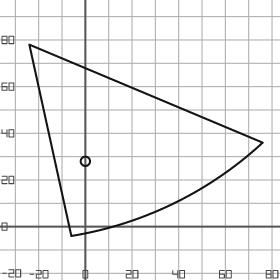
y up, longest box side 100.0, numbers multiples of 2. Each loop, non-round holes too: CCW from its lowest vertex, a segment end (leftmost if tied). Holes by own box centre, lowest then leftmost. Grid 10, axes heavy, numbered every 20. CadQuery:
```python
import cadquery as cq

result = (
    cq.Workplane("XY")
    .moveTo(-6.0, -4.0)
    .threePointArc((38.0, 10.0), (76.0, 36.0))
    .lineTo(-24.0, 78.0)
    .close()
    .moveTo(0.0, 28.0)
    .circle(2.0)
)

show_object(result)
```